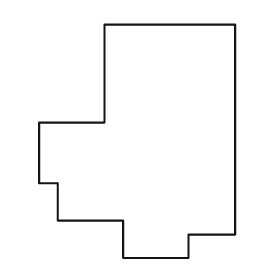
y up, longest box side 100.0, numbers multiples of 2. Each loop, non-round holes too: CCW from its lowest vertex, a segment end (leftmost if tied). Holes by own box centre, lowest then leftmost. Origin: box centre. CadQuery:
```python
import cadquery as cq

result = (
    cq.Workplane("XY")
    .moveTo(-6.0, -50.0)
    .lineTo(22.0, -50.0)
    .lineTo(22.0, -40.0)
    .lineTo(42.0, -40.0)
    .lineTo(42.0, 50.0)
    .lineTo(-14.0, 50.0)
    .lineTo(-14.0, 8.0)
    .lineTo(-42.0, 8.0)
    .lineTo(-42.0, -18.0)
    .lineTo(-34.0, -18.0)
    .lineTo(-34.0, -34.0)
    .lineTo(-6.0, -34.0)
    .close()
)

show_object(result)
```